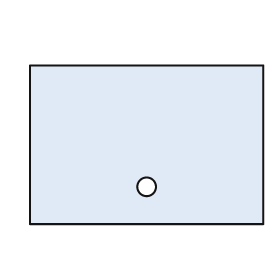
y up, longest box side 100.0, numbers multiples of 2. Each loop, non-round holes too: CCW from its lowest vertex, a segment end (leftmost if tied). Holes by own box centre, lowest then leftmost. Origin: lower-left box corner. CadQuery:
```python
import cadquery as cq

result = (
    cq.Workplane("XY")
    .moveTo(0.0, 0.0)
    .lineTo(100.0, 0.0)
    .lineTo(100.0, 68.0)
    .lineTo(0.0, 68.0)
    .close()
    .moveTo(50.0, 16.0)
    .circle(4.0)
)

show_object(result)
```